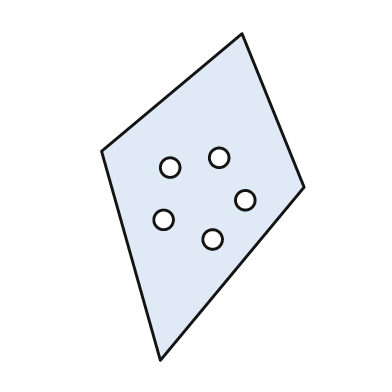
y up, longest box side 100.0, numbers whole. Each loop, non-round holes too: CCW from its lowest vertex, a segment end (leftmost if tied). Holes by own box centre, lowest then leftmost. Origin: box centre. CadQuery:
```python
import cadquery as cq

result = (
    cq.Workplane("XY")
    .moveTo(-13.0, -50.0)
    .lineTo(31.0, 3.0)
    .lineTo(12.0, 50.0)
    .lineTo(-31.0, 14.0)
    .close()
    .moveTo(3.0, -13.0)
    .circle(3.0)
    .moveTo(-12.0, -7.0)
    .circle(3.0)
    .moveTo(13.0, -1.0)
    .circle(3.0)
    .moveTo(-10.0, 9.0)
    .circle(3.0)
    .moveTo(5.0, 12.0)
    .circle(3.0)
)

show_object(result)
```